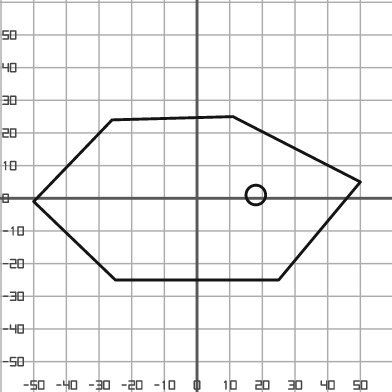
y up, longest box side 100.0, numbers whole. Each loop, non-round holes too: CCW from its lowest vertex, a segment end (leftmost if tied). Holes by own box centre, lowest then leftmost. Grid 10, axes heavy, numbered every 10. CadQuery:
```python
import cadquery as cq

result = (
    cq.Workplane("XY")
    .moveTo(-25.0, -25.0)
    .lineTo(25.0, -25.0)
    .lineTo(50.0, 5.0)
    .lineTo(11.0, 25.0)
    .lineTo(-26.0, 24.0)
    .lineTo(-50.0, -1.0)
    .close()
    .moveTo(18.0, 1.0)
    .circle(3.0)
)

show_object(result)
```